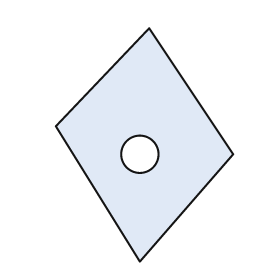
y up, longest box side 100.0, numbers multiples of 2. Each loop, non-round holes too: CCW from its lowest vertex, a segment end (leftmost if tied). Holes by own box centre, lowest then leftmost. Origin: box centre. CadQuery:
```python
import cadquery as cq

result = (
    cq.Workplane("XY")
    .moveTo(-2.0, -50.0)
    .lineTo(38.0, -4.0)
    .lineTo(2.0, 50.0)
    .lineTo(-38.0, 8.0)
    .close()
    .moveTo(-2.0, -4.0)
    .circle(8.0)
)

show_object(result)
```